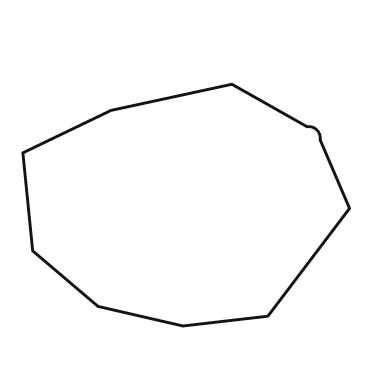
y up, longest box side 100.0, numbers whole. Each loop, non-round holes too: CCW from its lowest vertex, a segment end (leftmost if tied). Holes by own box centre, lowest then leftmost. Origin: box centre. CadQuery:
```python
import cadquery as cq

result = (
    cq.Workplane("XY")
    .moveTo(-1.0, -37.0)
    .lineTo(25.0, -34.0)
    .lineTo(50.0, -1.0)
    .lineTo(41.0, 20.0)
    .threePointArc((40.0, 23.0), (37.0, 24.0))
    .lineTo(14.0, 37.0)
    .lineTo(-23.0, 29.0)
    .lineTo(-50.0, 16.0)
    .lineTo(-47.0, -14.0)
    .lineTo(-27.0, -31.0)
    .close()
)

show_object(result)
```